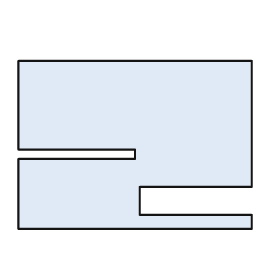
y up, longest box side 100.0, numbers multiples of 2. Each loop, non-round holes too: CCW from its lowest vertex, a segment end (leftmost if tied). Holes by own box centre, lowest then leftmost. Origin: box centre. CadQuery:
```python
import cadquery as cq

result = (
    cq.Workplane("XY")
    .moveTo(-50.0, -36.0)
    .lineTo(50.0, -36.0)
    .lineTo(50.0, -30.0)
    .lineTo(2.0, -30.0)
    .lineTo(2.0, -18.0)
    .lineTo(50.0, -18.0)
    .lineTo(50.0, 36.0)
    .lineTo(-50.0, 36.0)
    .lineTo(-50.0, -2.0)
    .lineTo(0.0, -2.0)
    .lineTo(0.0, -6.0)
    .lineTo(-50.0, -6.0)
    .close()
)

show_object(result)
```